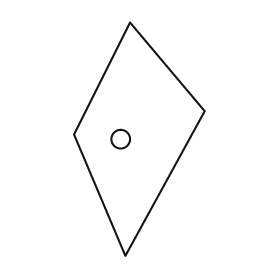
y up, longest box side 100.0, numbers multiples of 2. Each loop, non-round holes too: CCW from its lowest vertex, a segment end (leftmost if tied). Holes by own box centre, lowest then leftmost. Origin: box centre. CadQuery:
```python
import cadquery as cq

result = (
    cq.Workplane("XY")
    .moveTo(-6.0, -50.0)
    .lineTo(28.0, 12.0)
    .lineTo(-4.0, 50.0)
    .lineTo(-28.0, 2.0)
    .close()
    .moveTo(-8.0, 0.0)
    .circle(4.0)
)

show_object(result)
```